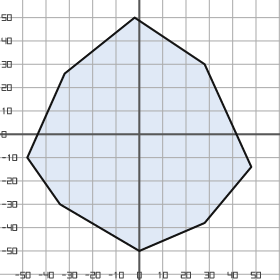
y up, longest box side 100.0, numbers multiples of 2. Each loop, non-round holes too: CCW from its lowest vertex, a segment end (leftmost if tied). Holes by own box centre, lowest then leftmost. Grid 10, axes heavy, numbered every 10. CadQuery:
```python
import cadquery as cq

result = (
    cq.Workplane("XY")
    .moveTo(0.0, -50.0)
    .lineTo(28.0, -38.0)
    .lineTo(48.0, -14.0)
    .lineTo(28.0, 30.0)
    .lineTo(-2.0, 50.0)
    .lineTo(-32.0, 26.0)
    .lineTo(-48.0, -10.0)
    .lineTo(-34.0, -30.0)
    .close()
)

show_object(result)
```